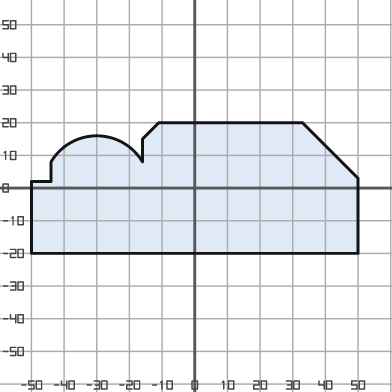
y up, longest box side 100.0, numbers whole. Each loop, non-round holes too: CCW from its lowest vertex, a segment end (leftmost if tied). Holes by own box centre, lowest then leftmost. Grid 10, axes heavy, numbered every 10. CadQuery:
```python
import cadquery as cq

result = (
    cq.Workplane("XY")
    .moveTo(-50.0, -20.0)
    .lineTo(50.0, -20.0)
    .lineTo(50.0, 3.0)
    .lineTo(33.0, 20.0)
    .lineTo(-11.0, 20.0)
    .lineTo(-16.0, 15.0)
    .lineTo(-16.0, 8.0)
    .threePointArc((-30.0, 16.0), (-44.0, 8.0))
    .lineTo(-44.0, 2.0)
    .lineTo(-50.0, 2.0)
    .close()
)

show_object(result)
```